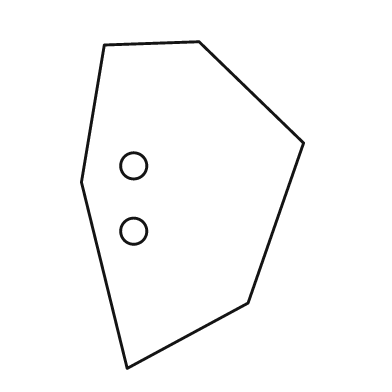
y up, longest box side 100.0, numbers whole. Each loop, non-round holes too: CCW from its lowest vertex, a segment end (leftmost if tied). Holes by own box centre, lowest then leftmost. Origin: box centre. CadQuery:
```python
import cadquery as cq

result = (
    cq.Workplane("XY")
    .moveTo(-20.0, -50.0)
    .lineTo(17.0, -30.0)
    .lineTo(34.0, 19.0)
    .lineTo(2.0, 50.0)
    .lineTo(-27.0, 49.0)
    .lineTo(-34.0, 7.0)
    .close()
    .moveTo(-18.0, -8.0)
    .circle(4.0)
    .moveTo(-18.0, 12.0)
    .circle(4.0)
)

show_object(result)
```